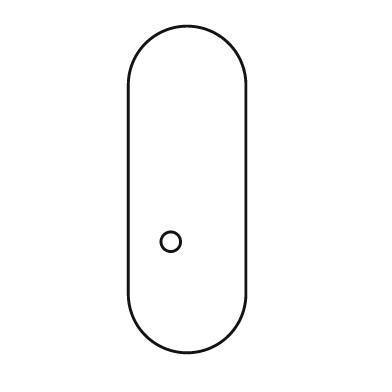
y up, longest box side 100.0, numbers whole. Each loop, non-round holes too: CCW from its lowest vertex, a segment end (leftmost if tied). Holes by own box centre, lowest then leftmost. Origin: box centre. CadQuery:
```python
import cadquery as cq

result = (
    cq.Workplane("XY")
    .moveTo(-18.0, -32.0)
    .threePointArc((0.0, -50.0), (18.0, -32.0))
    .lineTo(18.0, 32.0)
    .threePointArc((0.0, 50.0), (-18.0, 32.0))
    .close()
    .moveTo(-5.0, -16.0)
    .circle(3.0)
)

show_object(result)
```